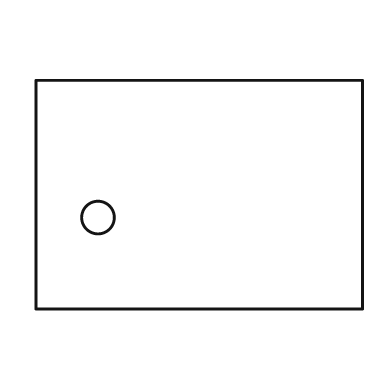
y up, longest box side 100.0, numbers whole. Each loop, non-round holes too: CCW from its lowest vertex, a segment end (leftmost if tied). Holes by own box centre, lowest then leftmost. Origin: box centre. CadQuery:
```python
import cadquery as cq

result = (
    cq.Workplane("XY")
    .moveTo(-50.0, -35.0)
    .lineTo(50.0, -35.0)
    .lineTo(50.0, 35.0)
    .lineTo(-50.0, 35.0)
    .close()
    .moveTo(-31.0, -7.0)
    .circle(5.0)
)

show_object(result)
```